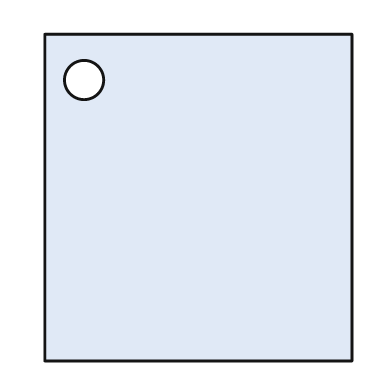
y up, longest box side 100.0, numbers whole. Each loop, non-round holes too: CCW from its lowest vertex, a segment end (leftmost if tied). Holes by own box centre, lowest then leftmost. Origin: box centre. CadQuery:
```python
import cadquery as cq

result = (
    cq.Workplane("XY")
    .moveTo(-47.0, -50.0)
    .lineTo(47.0, -50.0)
    .lineTo(47.0, 50.0)
    .lineTo(-47.0, 50.0)
    .close()
    .moveTo(-35.0, 36.0)
    .circle(6.0)
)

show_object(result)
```